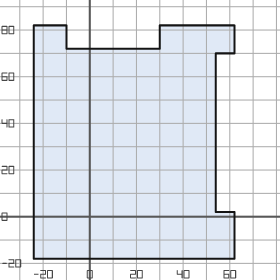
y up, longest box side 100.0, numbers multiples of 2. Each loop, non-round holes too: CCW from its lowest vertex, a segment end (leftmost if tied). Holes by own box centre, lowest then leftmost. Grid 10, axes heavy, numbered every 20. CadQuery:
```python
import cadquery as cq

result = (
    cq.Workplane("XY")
    .moveTo(-24.0, -18.0)
    .lineTo(62.0, -18.0)
    .lineTo(62.0, 2.0)
    .lineTo(54.0, 2.0)
    .lineTo(54.0, 70.0)
    .lineTo(62.0, 70.0)
    .lineTo(62.0, 82.0)
    .lineTo(30.0, 82.0)
    .lineTo(30.0, 72.0)
    .lineTo(-10.0, 72.0)
    .lineTo(-10.0, 82.0)
    .lineTo(-24.0, 82.0)
    .close()
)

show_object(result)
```